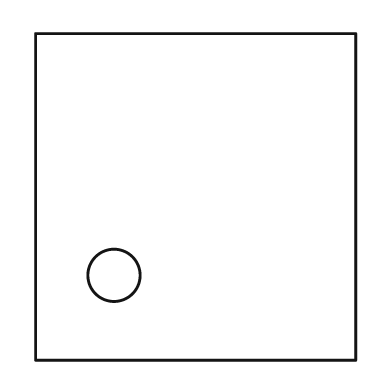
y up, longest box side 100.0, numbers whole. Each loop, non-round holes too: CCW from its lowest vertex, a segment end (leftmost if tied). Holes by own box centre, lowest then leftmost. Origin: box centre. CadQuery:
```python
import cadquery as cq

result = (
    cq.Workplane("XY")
    .moveTo(-49.0, -50.0)
    .lineTo(49.0, -50.0)
    .lineTo(49.0, 50.0)
    .lineTo(-49.0, 50.0)
    .close()
    .moveTo(-25.0, -24.0)
    .circle(8.0)
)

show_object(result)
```